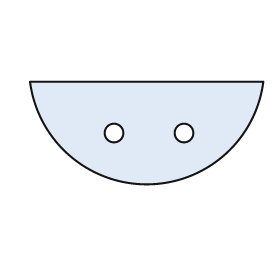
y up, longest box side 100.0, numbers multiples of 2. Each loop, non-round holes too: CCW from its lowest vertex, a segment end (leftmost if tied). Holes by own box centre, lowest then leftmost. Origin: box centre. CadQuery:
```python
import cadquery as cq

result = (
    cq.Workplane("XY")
    .moveTo(-50.0, 22.0)
    .threePointArc((0.0, -22.0), (50.0, 22.0))
    .close()
    .moveTo(-14.0, 0.0)
    .circle(4.0)
    .moveTo(16.0, 0.0)
    .circle(4.0)
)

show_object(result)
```